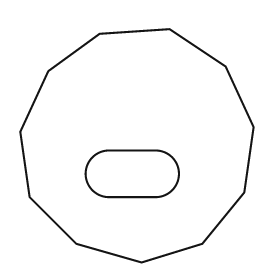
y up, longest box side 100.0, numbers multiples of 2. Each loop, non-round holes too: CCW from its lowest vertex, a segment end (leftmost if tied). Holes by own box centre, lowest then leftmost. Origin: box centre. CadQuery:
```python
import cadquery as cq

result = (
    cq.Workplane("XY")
    .moveTo(2.0, -50.0)
    .lineTo(28.0, -42.0)
    .lineTo(46.0, -20.0)
    .lineTo(50.0, 8.0)
    .lineTo(38.0, 34.0)
    .lineTo(14.0, 50.0)
    .lineTo(-16.0, 48.0)
    .lineTo(-38.0, 32.0)
    .lineTo(-50.0, 6.0)
    .lineTo(-46.0, -22.0)
    .lineTo(-26.0, -42.0)
    .close()
    .moveTo(-12.0, -22.0)
    .lineTo(8.0, -22.0)
    .threePointArc((18.0, -12.0), (8.0, -2.0))
    .lineTo(-12.0, -2.0)
    .threePointArc((-22.0, -12.0), (-12.0, -22.0))
    .close()
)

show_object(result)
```